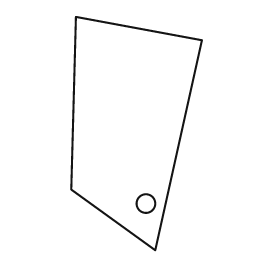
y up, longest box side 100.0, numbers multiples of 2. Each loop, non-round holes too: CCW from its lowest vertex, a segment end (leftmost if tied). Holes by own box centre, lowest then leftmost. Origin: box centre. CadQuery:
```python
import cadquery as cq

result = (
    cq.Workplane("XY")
    .moveTo(8.0, -50.0)
    .lineTo(28.0, 40.0)
    .lineTo(-26.0, 50.0)
    .lineTo(-28.0, -24.0)
    .close()
    .moveTo(4.0, -30.0)
    .circle(4.0)
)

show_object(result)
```